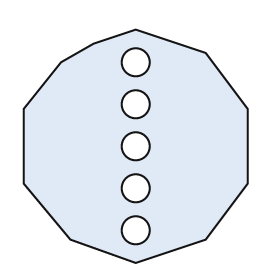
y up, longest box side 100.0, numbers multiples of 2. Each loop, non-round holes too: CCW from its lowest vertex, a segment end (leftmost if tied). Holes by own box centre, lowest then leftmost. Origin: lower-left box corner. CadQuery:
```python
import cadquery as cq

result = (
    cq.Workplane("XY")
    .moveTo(48.0, 0.0)
    .lineTo(78.0, 10.0)
    .lineTo(96.0, 34.0)
    .lineTo(96.0, 66.0)
    .lineTo(78.0, 90.0)
    .lineTo(48.0, 100.0)
    .lineTo(30.0, 94.0)
    .lineTo(16.0, 86.0)
    .lineTo(0.0, 66.0)
    .lineTo(0.0, 34.0)
    .lineTo(20.0, 10.0)
    .close()
    .moveTo(48.0, 14.0)
    .circle(6.0)
    .moveTo(48.0, 32.0)
    .circle(6.0)
    .moveTo(48.0, 50.0)
    .circle(6.0)
    .moveTo(48.0, 68.0)
    .circle(6.0)
    .moveTo(48.0, 86.0)
    .circle(6.0)
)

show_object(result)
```